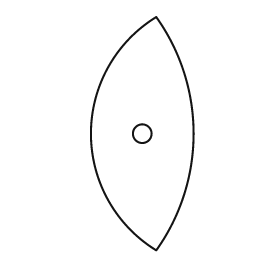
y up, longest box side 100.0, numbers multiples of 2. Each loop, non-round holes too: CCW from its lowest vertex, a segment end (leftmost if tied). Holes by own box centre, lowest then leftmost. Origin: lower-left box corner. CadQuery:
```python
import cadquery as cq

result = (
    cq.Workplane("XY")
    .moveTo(28.0, 0.0)
    .threePointArc((44.0, 50.0), (28.0, 100.0))
    .threePointArc((0.0, 50.0), (28.0, 0.0))
    .close()
    .moveTo(22.0, 50.0)
    .circle(4.0)
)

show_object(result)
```